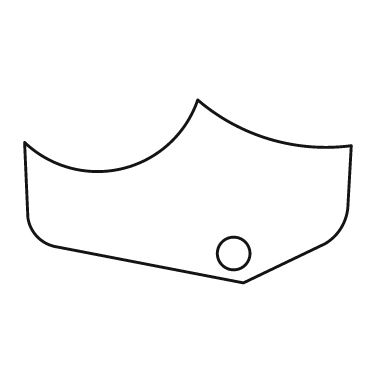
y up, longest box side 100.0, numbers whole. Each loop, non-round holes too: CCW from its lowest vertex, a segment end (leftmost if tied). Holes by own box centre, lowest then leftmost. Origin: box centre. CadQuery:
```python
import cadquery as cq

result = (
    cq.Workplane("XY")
    .moveTo(17.0, -28.0)
    .lineTo(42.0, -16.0)
    .threePointArc((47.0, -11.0), (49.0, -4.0))
    .lineTo(50.0, 14.0)
    .threePointArc((25.0, 16.0), (3.0, 28.0))
    .threePointArc((-20.0, 7.0), (-50.0, 15.0))
    .lineTo(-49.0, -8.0)
    .threePointArc((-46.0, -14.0), (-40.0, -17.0))
    .close()
    .moveTo(14.0, -19.0)
    .circle(5.0)
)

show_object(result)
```